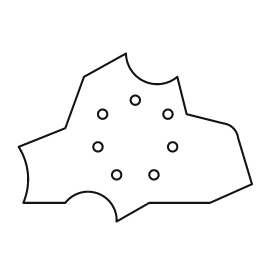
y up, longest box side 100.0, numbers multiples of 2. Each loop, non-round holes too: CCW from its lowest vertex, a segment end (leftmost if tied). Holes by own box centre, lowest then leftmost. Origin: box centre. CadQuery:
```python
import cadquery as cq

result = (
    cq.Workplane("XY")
    .moveTo(-8.0, -36.0)
    .lineTo(6.0, -28.0)
    .lineTo(32.0, -28.0)
    .lineTo(50.0, -20.0)
    .lineTo(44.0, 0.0)
    .threePointArc((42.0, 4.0), (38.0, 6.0))
    .lineTo(22.0, 10.0)
    .lineTo(18.0, 26.0)
    .threePointArc((4.0, 24.0), (-4.0, 36.0))
    .lineTo(-22.0, 26.0)
    .lineTo(-30.0, 4.0)
    .lineTo(-50.0, -4.0)
    .threePointArc((-46.0, -16.0), (-48.0, -28.0))
    .lineTo(-30.0, -28.0)
    .threePointArc((-16.0, -24.0), (-8.0, -36.0))
    .close()
    .moveTo(-8.0, -16.0)
    .circle(2.0)
    .moveTo(8.0, -16.0)
    .circle(2.0)
    .moveTo(-16.0, -4.0)
    .circle(2.0)
    .moveTo(16.0, -4.0)
    .circle(2.0)
    .moveTo(-14.0, 10.0)
    .circle(2.0)
    .moveTo(14.0, 10.0)
    .circle(2.0)
    .moveTo(0.0, 16.0)
    .circle(2.0)
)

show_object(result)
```